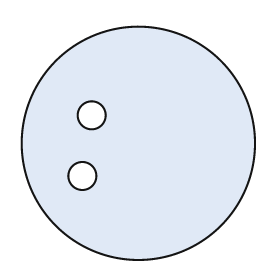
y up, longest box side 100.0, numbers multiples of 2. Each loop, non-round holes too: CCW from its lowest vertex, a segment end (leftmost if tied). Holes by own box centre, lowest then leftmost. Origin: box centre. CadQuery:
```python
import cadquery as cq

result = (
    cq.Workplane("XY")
    .moveTo(0.0, 0.0)
    .circle(50.0)
    .moveTo(-24.0, -14.0)
    .circle(6.0)
    .moveTo(-20.0, 12.0)
    .circle(6.0)
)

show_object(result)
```